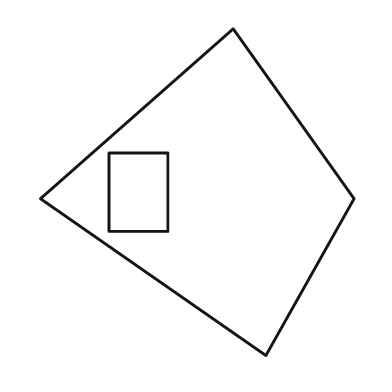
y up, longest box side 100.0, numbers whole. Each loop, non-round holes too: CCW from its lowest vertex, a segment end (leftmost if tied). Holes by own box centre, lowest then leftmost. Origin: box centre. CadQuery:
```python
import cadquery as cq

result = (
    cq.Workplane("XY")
    .moveTo(21.0, -50.0)
    .lineTo(48.0, -2.0)
    .lineTo(11.0, 50.0)
    .lineTo(-48.0, -2.0)
    .close()
    .moveTo(-27.0, -12.0)
    .lineTo(-9.0, -12.0)
    .lineTo(-9.0, 12.0)
    .lineTo(-27.0, 12.0)
    .close()
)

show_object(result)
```